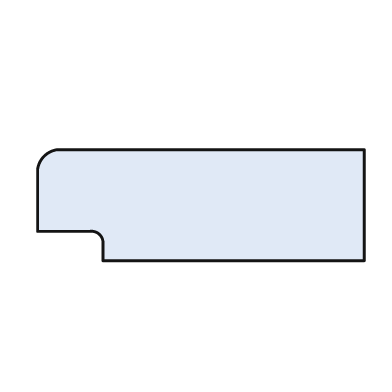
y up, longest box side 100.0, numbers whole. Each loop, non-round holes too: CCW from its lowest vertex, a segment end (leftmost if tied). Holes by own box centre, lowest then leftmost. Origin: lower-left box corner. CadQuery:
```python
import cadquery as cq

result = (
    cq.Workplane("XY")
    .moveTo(20.0, 0.0)
    .lineTo(100.0, 0.0)
    .lineTo(100.0, 34.0)
    .lineTo(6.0, 34.0)
    .threePointArc((2.0, 32.0), (0.0, 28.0))
    .lineTo(0.0, 9.0)
    .lineTo(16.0, 9.0)
    .threePointArc((19.0, 8.0), (20.0, 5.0))
    .close()
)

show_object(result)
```